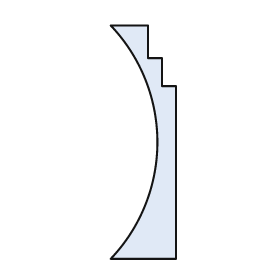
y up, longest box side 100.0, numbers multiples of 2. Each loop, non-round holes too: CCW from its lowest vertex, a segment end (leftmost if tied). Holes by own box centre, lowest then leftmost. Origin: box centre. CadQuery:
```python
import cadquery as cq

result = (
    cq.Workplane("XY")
    .moveTo(-14.0, -50.0)
    .lineTo(14.0, -50.0)
    .lineTo(14.0, 24.0)
    .lineTo(8.0, 24.0)
    .lineTo(8.0, 36.0)
    .lineTo(2.0, 36.0)
    .lineTo(2.0, 50.0)
    .lineTo(-14.0, 50.0)
    .threePointArc((6.0, 0.0), (-14.0, -50.0))
    .close()
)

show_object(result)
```